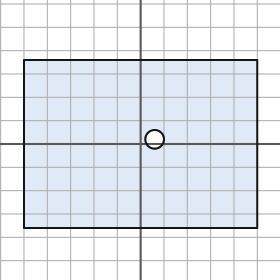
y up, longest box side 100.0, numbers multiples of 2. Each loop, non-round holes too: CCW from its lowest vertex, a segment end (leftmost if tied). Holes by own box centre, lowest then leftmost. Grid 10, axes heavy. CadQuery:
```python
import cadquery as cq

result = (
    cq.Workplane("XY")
    .moveTo(-50.0, -36.0)
    .lineTo(50.0, -36.0)
    .lineTo(50.0, 36.0)
    .lineTo(-50.0, 36.0)
    .close()
    .moveTo(6.0, 2.0)
    .circle(4.0)
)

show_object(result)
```